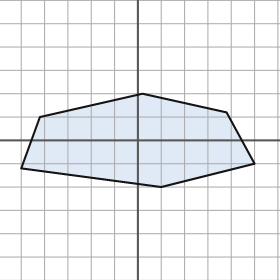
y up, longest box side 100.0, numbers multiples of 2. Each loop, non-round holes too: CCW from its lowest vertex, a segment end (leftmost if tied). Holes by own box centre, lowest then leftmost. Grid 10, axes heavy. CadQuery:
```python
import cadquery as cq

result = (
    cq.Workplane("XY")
    .moveTo(10.0, -20.0)
    .lineTo(50.0, -10.0)
    .lineTo(38.0, 12.0)
    .lineTo(2.0, 20.0)
    .lineTo(-42.0, 10.0)
    .lineTo(-50.0, -12.0)
    .close()
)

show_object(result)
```